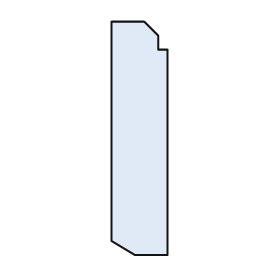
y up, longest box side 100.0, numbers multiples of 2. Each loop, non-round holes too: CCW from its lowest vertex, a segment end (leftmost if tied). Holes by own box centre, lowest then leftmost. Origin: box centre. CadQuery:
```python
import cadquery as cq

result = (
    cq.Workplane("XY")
    .moveTo(-2.0, -50.0)
    .lineTo(12.0, -50.0)
    .lineTo(12.0, 38.0)
    .lineTo(8.0, 38.0)
    .lineTo(8.0, 44.0)
    .lineTo(2.0, 50.0)
    .lineTo(-12.0, 50.0)
    .lineTo(-12.0, -44.0)
    .close()
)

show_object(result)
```